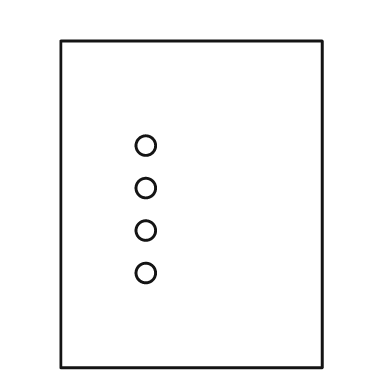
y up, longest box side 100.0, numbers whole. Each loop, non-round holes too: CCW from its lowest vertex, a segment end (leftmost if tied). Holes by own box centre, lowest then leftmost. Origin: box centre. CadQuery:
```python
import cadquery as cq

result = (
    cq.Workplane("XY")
    .moveTo(-40.0, -50.0)
    .lineTo(40.0, -50.0)
    .lineTo(40.0, 50.0)
    .lineTo(-40.0, 50.0)
    .close()
    .moveTo(-14.0, -21.0)
    .circle(3.0)
    .moveTo(-14.0, -8.0)
    .circle(3.0)
    .moveTo(-14.0, 5.0)
    .circle(3.0)
    .moveTo(-14.0, 18.0)
    .circle(3.0)
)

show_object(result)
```